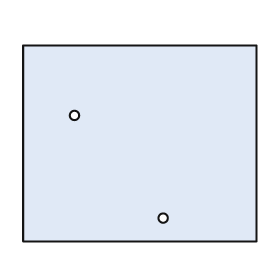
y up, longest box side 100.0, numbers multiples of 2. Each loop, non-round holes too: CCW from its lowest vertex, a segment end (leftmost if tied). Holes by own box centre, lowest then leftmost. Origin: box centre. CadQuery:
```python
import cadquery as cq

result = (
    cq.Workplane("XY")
    .moveTo(-50.0, -42.0)
    .lineTo(50.0, -42.0)
    .lineTo(50.0, 42.0)
    .lineTo(-50.0, 42.0)
    .close()
    .moveTo(10.0, -32.0)
    .circle(2.0)
    .moveTo(-28.0, 12.0)
    .circle(2.0)
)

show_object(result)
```